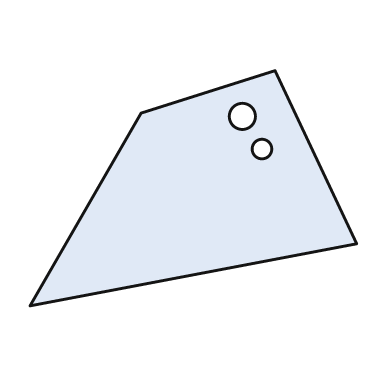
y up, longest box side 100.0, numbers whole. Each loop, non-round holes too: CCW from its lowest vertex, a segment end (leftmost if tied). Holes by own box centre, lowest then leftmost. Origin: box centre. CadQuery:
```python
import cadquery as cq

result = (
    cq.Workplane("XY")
    .moveTo(-50.0, -36.0)
    .lineTo(50.0, -17.0)
    .lineTo(25.0, 36.0)
    .lineTo(-16.0, 23.0)
    .close()
    .moveTo(21.0, 12.0)
    .circle(3.0)
    .moveTo(15.0, 22.0)
    .circle(4.0)
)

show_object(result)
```